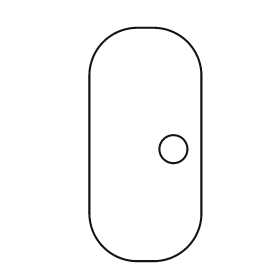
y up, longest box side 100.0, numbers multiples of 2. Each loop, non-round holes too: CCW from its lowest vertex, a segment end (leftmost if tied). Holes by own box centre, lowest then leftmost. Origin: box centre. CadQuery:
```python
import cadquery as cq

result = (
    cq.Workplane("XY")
    .moveTo(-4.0, -50.0)
    .lineTo(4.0, -50.0)
    .threePointArc((18.0, -44.0), (24.0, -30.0))
    .lineTo(24.0, 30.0)
    .threePointArc((18.0, 44.0), (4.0, 50.0))
    .lineTo(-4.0, 50.0)
    .threePointArc((-18.0, 44.0), (-24.0, 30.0))
    .lineTo(-24.0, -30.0)
    .threePointArc((-18.0, -44.0), (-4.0, -50.0))
    .close()
    .moveTo(12.0, -2.0)
    .circle(6.0)
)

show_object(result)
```